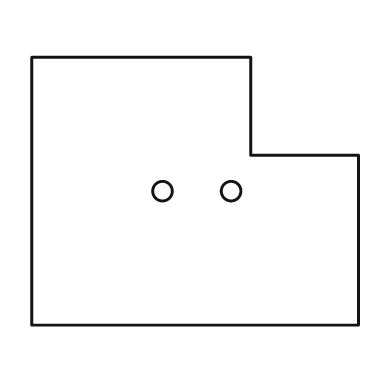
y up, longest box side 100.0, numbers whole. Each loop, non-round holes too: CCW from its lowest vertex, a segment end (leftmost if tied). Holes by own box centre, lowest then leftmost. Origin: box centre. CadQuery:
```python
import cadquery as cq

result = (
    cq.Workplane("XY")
    .moveTo(-50.0, -41.0)
    .lineTo(50.0, -41.0)
    .lineTo(50.0, 11.0)
    .lineTo(17.0, 11.0)
    .lineTo(17.0, 41.0)
    .lineTo(-50.0, 41.0)
    .close()
    .moveTo(-10.0, 0.0)
    .circle(3.0)
    .moveTo(11.0, 0.0)
    .circle(3.0)
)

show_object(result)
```